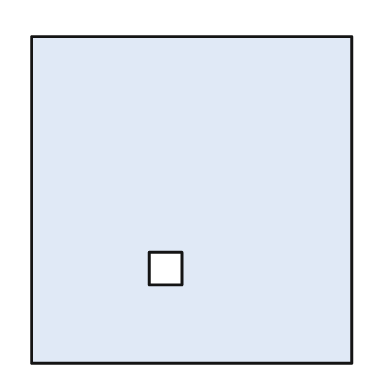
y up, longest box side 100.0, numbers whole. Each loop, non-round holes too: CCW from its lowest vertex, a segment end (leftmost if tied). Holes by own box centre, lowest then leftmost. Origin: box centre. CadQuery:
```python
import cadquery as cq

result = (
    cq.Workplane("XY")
    .moveTo(-49.0, -50.0)
    .lineTo(49.0, -50.0)
    .lineTo(49.0, 50.0)
    .lineTo(-49.0, 50.0)
    .close()
    .moveTo(-13.0, -26.0)
    .lineTo(-3.0, -26.0)
    .lineTo(-3.0, -16.0)
    .lineTo(-13.0, -16.0)
    .close()
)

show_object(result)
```